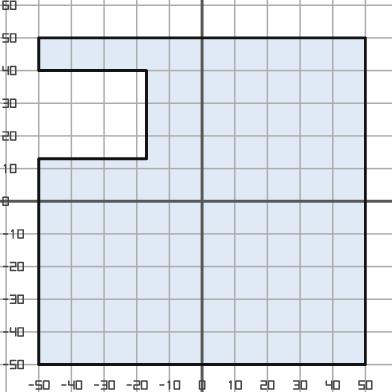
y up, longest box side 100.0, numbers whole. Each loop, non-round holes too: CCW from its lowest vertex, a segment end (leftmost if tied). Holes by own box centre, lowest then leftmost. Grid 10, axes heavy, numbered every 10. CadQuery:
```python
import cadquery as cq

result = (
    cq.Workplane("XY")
    .moveTo(-50.0, -50.0)
    .lineTo(50.0, -50.0)
    .lineTo(50.0, 50.0)
    .lineTo(-50.0, 50.0)
    .lineTo(-50.0, 40.0)
    .lineTo(-17.0, 40.0)
    .lineTo(-17.0, 13.0)
    .lineTo(-50.0, 13.0)
    .close()
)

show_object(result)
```